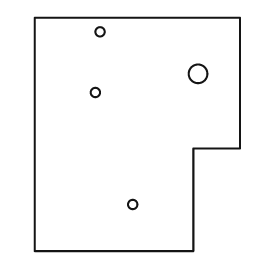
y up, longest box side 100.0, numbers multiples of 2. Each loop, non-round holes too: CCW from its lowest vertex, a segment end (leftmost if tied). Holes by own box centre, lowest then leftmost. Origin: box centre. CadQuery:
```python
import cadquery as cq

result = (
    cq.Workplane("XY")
    .moveTo(-44.0, -50.0)
    .lineTo(24.0, -50.0)
    .lineTo(24.0, -6.0)
    .lineTo(44.0, -6.0)
    .lineTo(44.0, 50.0)
    .lineTo(-44.0, 50.0)
    .close()
    .moveTo(-2.0, -30.0)
    .circle(2.0)
    .moveTo(-18.0, 18.0)
    .circle(2.0)
    .moveTo(26.0, 26.0)
    .circle(4.0)
    .moveTo(-16.0, 44.0)
    .circle(2.0)
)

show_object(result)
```